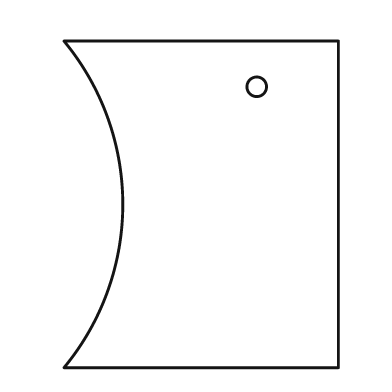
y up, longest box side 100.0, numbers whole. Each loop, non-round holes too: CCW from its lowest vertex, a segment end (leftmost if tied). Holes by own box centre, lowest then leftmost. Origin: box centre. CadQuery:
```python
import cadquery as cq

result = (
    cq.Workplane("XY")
    .moveTo(-42.0, -50.0)
    .lineTo(42.0, -50.0)
    .lineTo(42.0, 50.0)
    .lineTo(-42.0, 50.0)
    .threePointArc((-24.0, 0.0), (-42.0, -50.0))
    .close()
    .moveTo(17.0, 36.0)
    .circle(3.0)
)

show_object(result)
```